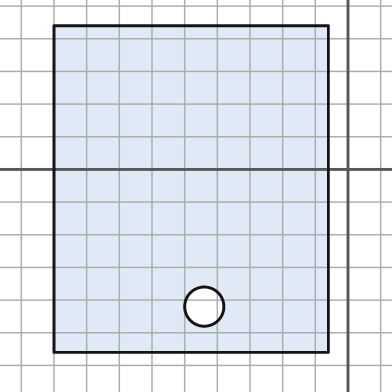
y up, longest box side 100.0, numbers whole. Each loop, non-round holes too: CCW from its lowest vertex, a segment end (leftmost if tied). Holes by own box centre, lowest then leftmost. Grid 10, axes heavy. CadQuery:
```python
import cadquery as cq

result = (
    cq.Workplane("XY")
    .moveTo(-90.0, -56.0)
    .lineTo(-6.0, -56.0)
    .lineTo(-6.0, 44.0)
    .lineTo(-90.0, 44.0)
    .close()
    .moveTo(-44.0, -42.0)
    .circle(6.0)
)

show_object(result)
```